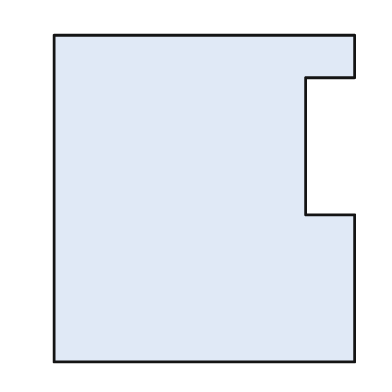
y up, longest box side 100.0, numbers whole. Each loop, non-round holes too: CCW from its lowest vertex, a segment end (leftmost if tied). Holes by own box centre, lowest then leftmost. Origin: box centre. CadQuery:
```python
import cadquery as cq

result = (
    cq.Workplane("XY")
    .moveTo(-46.0, -50.0)
    .lineTo(46.0, -50.0)
    .lineTo(46.0, -5.0)
    .lineTo(31.0, -5.0)
    .lineTo(31.0, 37.0)
    .lineTo(46.0, 37.0)
    .lineTo(46.0, 50.0)
    .lineTo(-46.0, 50.0)
    .close()
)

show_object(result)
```